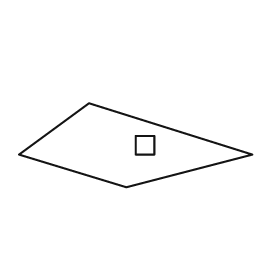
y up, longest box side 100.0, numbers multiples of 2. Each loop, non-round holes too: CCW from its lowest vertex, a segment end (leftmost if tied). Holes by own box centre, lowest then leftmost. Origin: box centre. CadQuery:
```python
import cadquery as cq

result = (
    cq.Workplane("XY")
    .moveTo(-4.0, -18.0)
    .lineTo(50.0, -4.0)
    .lineTo(-20.0, 18.0)
    .lineTo(-50.0, -4.0)
    .close()
    .moveTo(0.0, -4.0)
    .lineTo(8.0, -4.0)
    .lineTo(8.0, 4.0)
    .lineTo(0.0, 4.0)
    .close()
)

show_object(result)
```